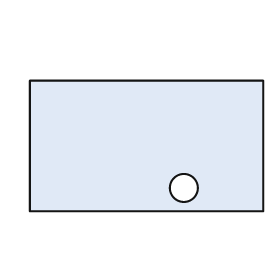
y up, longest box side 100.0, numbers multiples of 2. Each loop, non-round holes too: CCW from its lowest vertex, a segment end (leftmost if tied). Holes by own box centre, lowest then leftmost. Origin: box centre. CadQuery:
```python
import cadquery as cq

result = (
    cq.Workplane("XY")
    .moveTo(-50.0, -28.0)
    .lineTo(50.0, -28.0)
    .lineTo(50.0, 28.0)
    .lineTo(-50.0, 28.0)
    .close()
    .moveTo(16.0, -18.0)
    .circle(6.0)
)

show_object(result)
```